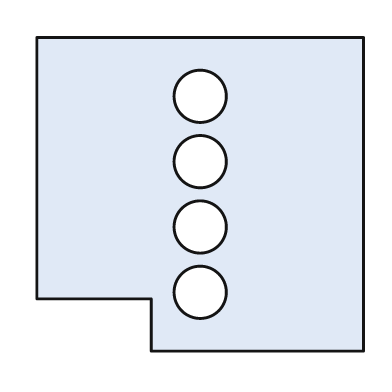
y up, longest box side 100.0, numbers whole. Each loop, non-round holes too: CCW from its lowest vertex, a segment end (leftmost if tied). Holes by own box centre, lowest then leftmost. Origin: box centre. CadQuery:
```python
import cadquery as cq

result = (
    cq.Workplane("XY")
    .moveTo(-15.0, -48.0)
    .lineTo(50.0, -48.0)
    .lineTo(50.0, 48.0)
    .lineTo(-50.0, 48.0)
    .lineTo(-50.0, -32.0)
    .lineTo(-15.0, -32.0)
    .close()
    .moveTo(0.0, -30.0)
    .circle(8.0)
    .moveTo(0.0, -10.0)
    .circle(8.0)
    .moveTo(0.0, 10.0)
    .circle(8.0)
    .moveTo(0.0, 30.0)
    .circle(8.0)
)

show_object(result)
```